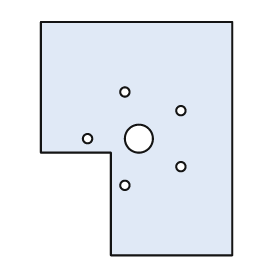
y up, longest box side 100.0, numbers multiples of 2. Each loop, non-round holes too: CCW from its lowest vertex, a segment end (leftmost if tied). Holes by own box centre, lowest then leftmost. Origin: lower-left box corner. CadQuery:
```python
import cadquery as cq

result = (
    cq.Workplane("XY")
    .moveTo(30.0, 0.0)
    .lineTo(82.0, 0.0)
    .lineTo(82.0, 100.0)
    .lineTo(0.0, 100.0)
    .lineTo(0.0, 44.0)
    .lineTo(30.0, 44.0)
    .close()
    .moveTo(36.0, 30.0)
    .circle(2.0)
    .moveTo(60.0, 38.0)
    .circle(2.0)
    .moveTo(20.0, 50.0)
    .circle(2.0)
    .moveTo(42.0, 50.0)
    .circle(6.0)
    .moveTo(60.0, 62.0)
    .circle(2.0)
    .moveTo(36.0, 70.0)
    .circle(2.0)
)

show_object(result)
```